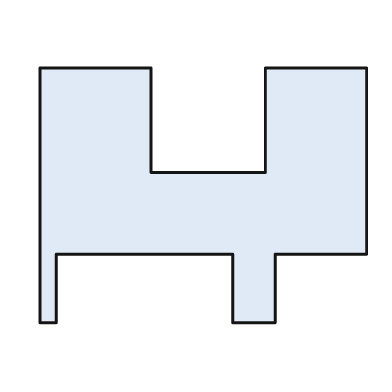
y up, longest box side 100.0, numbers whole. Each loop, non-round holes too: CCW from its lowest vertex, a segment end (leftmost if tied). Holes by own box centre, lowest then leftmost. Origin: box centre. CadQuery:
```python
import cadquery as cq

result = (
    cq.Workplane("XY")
    .moveTo(-50.0, -39.0)
    .lineTo(-45.0, -39.0)
    .lineTo(-45.0, -18.0)
    .lineTo(9.0, -18.0)
    .lineTo(9.0, -39.0)
    .lineTo(22.0, -39.0)
    .lineTo(22.0, -18.0)
    .lineTo(50.0, -18.0)
    .lineTo(50.0, 39.0)
    .lineTo(19.0, 39.0)
    .lineTo(19.0, 7.0)
    .lineTo(-16.0, 7.0)
    .lineTo(-16.0, 39.0)
    .lineTo(-50.0, 39.0)
    .close()
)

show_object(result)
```